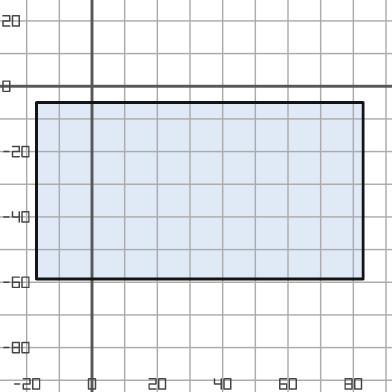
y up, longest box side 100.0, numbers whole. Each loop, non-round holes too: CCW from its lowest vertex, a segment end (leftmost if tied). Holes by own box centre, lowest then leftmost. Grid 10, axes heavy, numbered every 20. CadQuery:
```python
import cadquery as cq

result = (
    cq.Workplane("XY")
    .moveTo(-17.0, -59.0)
    .lineTo(83.0, -59.0)
    .lineTo(83.0, -5.0)
    .lineTo(-17.0, -5.0)
    .close()
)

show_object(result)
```